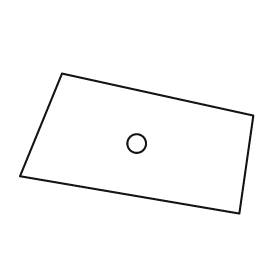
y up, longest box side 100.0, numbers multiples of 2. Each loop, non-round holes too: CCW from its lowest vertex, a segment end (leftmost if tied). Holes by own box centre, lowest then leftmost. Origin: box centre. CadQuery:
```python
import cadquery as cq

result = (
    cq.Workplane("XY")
    .moveTo(44.0, -30.0)
    .lineTo(50.0, 12.0)
    .lineTo(-32.0, 30.0)
    .lineTo(-50.0, -14.0)
    .close()
    .moveTo(0.0, 0.0)
    .circle(4.0)
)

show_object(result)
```